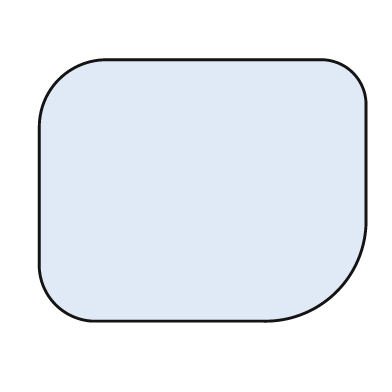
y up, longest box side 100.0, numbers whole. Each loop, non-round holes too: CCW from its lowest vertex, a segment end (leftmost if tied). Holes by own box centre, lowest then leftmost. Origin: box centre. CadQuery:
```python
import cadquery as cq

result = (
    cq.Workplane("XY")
    .moveTo(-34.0, -40.0)
    .lineTo(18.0, -40.0)
    .threePointArc((41.0, -31.0), (50.0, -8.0))
    .lineTo(50.0, 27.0)
    .threePointArc((46.0, 36.0), (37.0, 40.0))
    .lineTo(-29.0, 40.0)
    .threePointArc((-44.0, 34.0), (-50.0, 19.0))
    .lineTo(-50.0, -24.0)
    .threePointArc((-45.0, -35.0), (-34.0, -40.0))
    .close()
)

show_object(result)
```